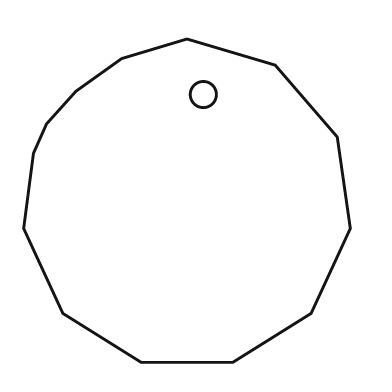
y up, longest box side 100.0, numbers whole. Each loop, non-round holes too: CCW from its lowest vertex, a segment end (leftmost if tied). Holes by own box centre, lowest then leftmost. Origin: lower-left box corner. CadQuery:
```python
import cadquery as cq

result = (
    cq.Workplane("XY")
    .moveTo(36.0, 0.0)
    .lineTo(64.0, 0.0)
    .lineTo(88.0, 15.0)
    .lineTo(100.0, 41.0)
    .lineTo(96.0, 69.0)
    .lineTo(77.0, 91.0)
    .lineTo(50.0, 99.0)
    .lineTo(30.0, 93.0)
    .lineTo(16.0, 83.0)
    .lineTo(7.0, 73.0)
    .lineTo(3.0, 64.0)
    .lineTo(0.0, 41.0)
    .lineTo(12.0, 15.0)
    .close()
    .moveTo(55.0, 82.0)
    .circle(4.0)
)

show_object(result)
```